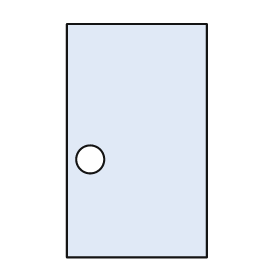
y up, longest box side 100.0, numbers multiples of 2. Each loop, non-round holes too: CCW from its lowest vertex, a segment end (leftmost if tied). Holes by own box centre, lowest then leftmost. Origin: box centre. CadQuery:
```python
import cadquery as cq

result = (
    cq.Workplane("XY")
    .moveTo(-30.0, -50.0)
    .lineTo(30.0, -50.0)
    .lineTo(30.0, 50.0)
    .lineTo(-30.0, 50.0)
    .close()
    .moveTo(-20.0, -8.0)
    .circle(6.0)
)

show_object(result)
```